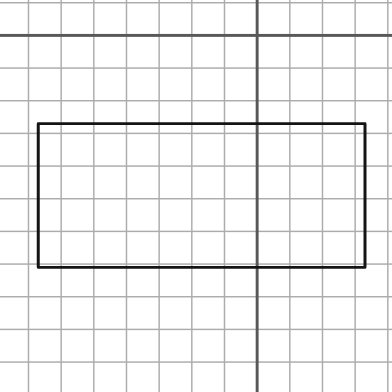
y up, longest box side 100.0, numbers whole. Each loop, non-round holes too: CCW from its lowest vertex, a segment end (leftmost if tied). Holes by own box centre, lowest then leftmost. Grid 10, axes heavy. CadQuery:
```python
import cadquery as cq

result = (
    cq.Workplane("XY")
    .moveTo(-67.0, -71.0)
    .lineTo(33.0, -71.0)
    .lineTo(33.0, -27.0)
    .lineTo(-67.0, -27.0)
    .close()
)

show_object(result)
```